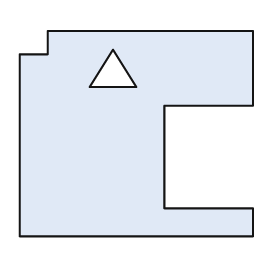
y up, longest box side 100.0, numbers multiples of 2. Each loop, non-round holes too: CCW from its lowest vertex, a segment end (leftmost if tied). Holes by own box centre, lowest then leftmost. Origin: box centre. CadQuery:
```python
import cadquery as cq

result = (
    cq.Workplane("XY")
    .moveTo(-50.0, -44.0)
    .lineTo(50.0, -44.0)
    .lineTo(50.0, -32.0)
    .lineTo(12.0, -32.0)
    .lineTo(12.0, 12.0)
    .lineTo(50.0, 12.0)
    .lineTo(50.0, 44.0)
    .lineTo(-38.0, 44.0)
    .lineTo(-38.0, 34.0)
    .lineTo(-50.0, 34.0)
    .close()
    .moveTo(-20.0, 20.0)
    .lineTo(0.0, 20.0)
    .lineTo(-10.0, 36.0)
    .close()
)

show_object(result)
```